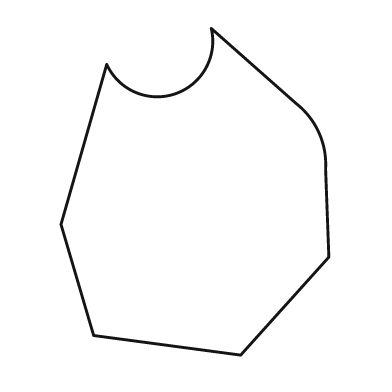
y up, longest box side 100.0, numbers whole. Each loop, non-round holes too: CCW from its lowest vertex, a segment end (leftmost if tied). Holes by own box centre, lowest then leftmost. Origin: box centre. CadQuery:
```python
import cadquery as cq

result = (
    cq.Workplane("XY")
    .moveTo(14.0, -50.0)
    .lineTo(41.0, -20.0)
    .lineTo(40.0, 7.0)
    .threePointArc((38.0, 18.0), (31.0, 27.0))
    .lineTo(5.0, 50.0)
    .threePointArc((-6.0, 30.0), (-27.0, 39.0))
    .lineTo(-41.0, -10.0)
    .lineTo(-31.0, -44.0)
    .close()
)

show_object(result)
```